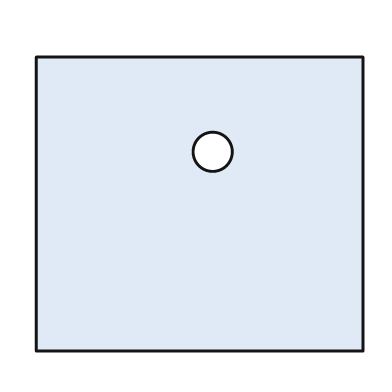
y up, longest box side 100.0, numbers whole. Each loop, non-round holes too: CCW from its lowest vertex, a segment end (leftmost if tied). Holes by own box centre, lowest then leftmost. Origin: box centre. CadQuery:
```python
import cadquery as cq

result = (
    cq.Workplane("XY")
    .moveTo(-50.0, -45.0)
    .lineTo(50.0, -45.0)
    .lineTo(50.0, 45.0)
    .lineTo(-50.0, 45.0)
    .close()
    .moveTo(4.0, 16.0)
    .circle(6.0)
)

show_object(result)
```